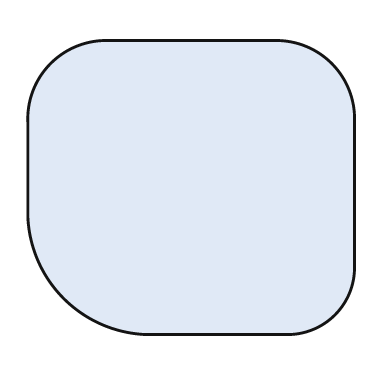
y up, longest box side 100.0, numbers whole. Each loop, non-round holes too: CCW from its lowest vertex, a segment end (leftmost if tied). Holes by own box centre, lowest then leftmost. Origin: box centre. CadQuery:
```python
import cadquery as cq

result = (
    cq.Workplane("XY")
    .moveTo(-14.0, -45.0)
    .lineTo(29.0, -45.0)
    .threePointArc((44.0, -39.0), (50.0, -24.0))
    .lineTo(50.0, 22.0)
    .threePointArc((43.0, 38.0), (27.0, 45.0))
    .lineTo(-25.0, 45.0)
    .threePointArc((-43.0, 38.0), (-50.0, 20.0))
    .lineTo(-50.0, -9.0)
    .threePointArc((-39.0, -34.0), (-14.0, -45.0))
    .close()
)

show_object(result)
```